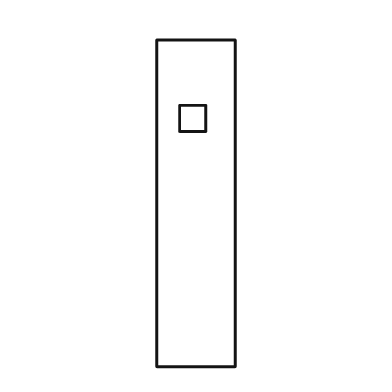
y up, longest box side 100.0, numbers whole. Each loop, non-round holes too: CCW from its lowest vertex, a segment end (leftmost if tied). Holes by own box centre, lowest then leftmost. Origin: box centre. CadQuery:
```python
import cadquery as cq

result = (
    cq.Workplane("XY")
    .moveTo(-12.0, -50.0)
    .lineTo(12.0, -50.0)
    .lineTo(12.0, 50.0)
    .lineTo(-12.0, 50.0)
    .close()
    .moveTo(-5.0, 22.0)
    .lineTo(3.0, 22.0)
    .lineTo(3.0, 30.0)
    .lineTo(-5.0, 30.0)
    .close()
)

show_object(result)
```